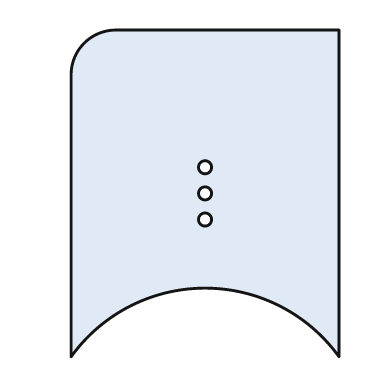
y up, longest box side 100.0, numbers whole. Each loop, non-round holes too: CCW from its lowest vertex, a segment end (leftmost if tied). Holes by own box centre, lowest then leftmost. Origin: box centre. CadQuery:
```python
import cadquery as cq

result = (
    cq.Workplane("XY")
    .moveTo(-41.0, -50.0)
    .threePointArc((0.0, -29.0), (41.0, -50.0))
    .lineTo(41.0, 50.0)
    .lineTo(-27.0, 50.0)
    .threePointArc((-37.0, 46.0), (-41.0, 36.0))
    .close()
    .moveTo(0.0, -8.0)
    .circle(2.0)
    .moveTo(0.0, 0.0)
    .circle(2.0)
    .moveTo(0.0, 8.0)
    .circle(2.0)
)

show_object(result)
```